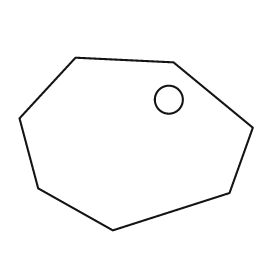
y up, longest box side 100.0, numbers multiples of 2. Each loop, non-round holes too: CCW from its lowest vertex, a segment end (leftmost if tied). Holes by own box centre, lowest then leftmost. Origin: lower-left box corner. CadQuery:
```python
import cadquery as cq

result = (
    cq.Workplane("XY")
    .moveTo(40.0, 0.0)
    .lineTo(90.0, 16.0)
    .lineTo(100.0, 44.0)
    .lineTo(66.0, 72.0)
    .lineTo(24.0, 74.0)
    .lineTo(0.0, 48.0)
    .lineTo(8.0, 18.0)
    .close()
    .moveTo(64.0, 56.0)
    .circle(6.0)
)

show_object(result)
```